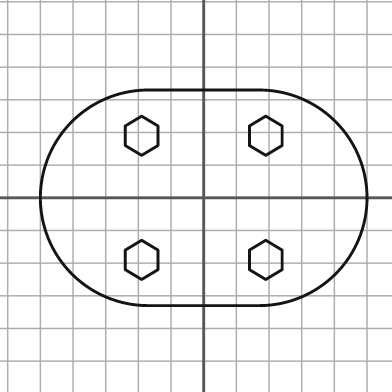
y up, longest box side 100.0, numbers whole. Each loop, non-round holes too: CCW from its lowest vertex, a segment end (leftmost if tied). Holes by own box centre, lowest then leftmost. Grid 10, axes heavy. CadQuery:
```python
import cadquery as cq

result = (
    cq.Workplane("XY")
    .moveTo(-17.0, -33.0)
    .lineTo(17.0, -33.0)
    .threePointArc((50.0, 0.0), (17.0, 33.0))
    .lineTo(-17.0, 33.0)
    .threePointArc((-50.0, 0.0), (-17.0, -33.0))
    .close()
    .moveTo(-19.0, -25.0)
    .lineTo(-14.0, -22.0)
    .lineTo(-14.0, -16.0)
    .lineTo(-19.0, -13.0)
    .lineTo(-24.0, -16.0)
    .lineTo(-24.0, -22.0)
    .close()
    .moveTo(19.0, -25.0)
    .lineTo(24.0, -22.0)
    .lineTo(24.0, -16.0)
    .lineTo(19.0, -13.0)
    .lineTo(14.0, -16.0)
    .lineTo(14.0, -22.0)
    .close()
    .moveTo(-19.0, 13.0)
    .lineTo(-14.0, 16.0)
    .lineTo(-14.0, 22.0)
    .lineTo(-19.0, 25.0)
    .lineTo(-24.0, 22.0)
    .lineTo(-24.0, 16.0)
    .close()
    .moveTo(19.0, 13.0)
    .lineTo(24.0, 16.0)
    .lineTo(24.0, 22.0)
    .lineTo(19.0, 25.0)
    .lineTo(14.0, 22.0)
    .lineTo(14.0, 16.0)
    .close()
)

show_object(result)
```